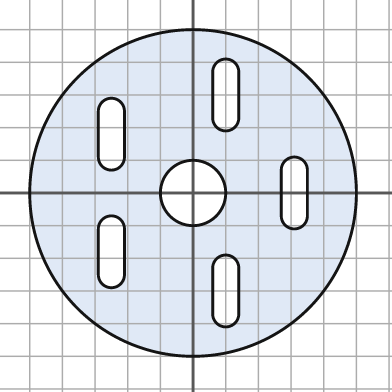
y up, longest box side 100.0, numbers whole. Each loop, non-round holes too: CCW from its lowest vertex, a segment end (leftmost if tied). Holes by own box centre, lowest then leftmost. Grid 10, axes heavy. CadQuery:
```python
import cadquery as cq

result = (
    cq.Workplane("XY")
    .moveTo(0.0, 0.0)
    .circle(50.0)
    .moveTo(6.0, -37.0)
    .threePointArc((10.0, -41.0), (14.0, -37.0))
    .lineTo(14.0, -23.0)
    .threePointArc((10.0, -19.0), (6.0, -23.0))
    .close()
    .moveTo(-29.0, -25.0)
    .threePointArc((-25.0, -29.0), (-21.0, -25.0))
    .lineTo(-21.0, -11.0)
    .threePointArc((-25.0, -7.0), (-29.0, -11.0))
    .close()
    .moveTo(0.0, 0.0)
    .circle(10.0)
    .moveTo(27.0, -7.0)
    .threePointArc((31.0, -11.0), (35.0, -7.0))
    .lineTo(35.0, 7.0)
    .threePointArc((31.0, 11.0), (27.0, 7.0))
    .close()
    .moveTo(-29.0, 11.0)
    .threePointArc((-25.0, 7.0), (-21.0, 11.0))
    .lineTo(-21.0, 25.0)
    .threePointArc((-25.0, 29.0), (-29.0, 25.0))
    .close()
    .moveTo(6.0, 23.0)
    .threePointArc((10.0, 19.0), (14.0, 23.0))
    .lineTo(14.0, 37.0)
    .threePointArc((10.0, 41.0), (6.0, 37.0))
    .close()
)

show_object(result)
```